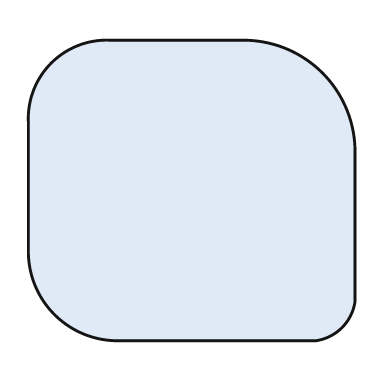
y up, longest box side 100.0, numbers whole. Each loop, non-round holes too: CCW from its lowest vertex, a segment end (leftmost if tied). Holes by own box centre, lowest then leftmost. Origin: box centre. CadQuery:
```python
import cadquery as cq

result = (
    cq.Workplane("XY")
    .moveTo(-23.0, -46.0)
    .lineTo(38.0, -46.0)
    .threePointArc((46.0, -42.0), (50.0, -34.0))
    .lineTo(50.0, 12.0)
    .threePointArc((40.0, 36.0), (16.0, 46.0))
    .lineTo(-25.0, 46.0)
    .threePointArc((-43.0, 39.0), (-50.0, 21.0))
    .lineTo(-50.0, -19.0)
    .threePointArc((-42.0, -38.0), (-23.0, -46.0))
    .close()
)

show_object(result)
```